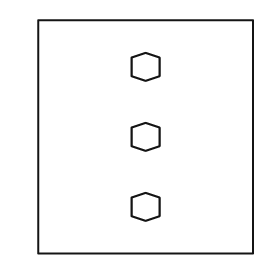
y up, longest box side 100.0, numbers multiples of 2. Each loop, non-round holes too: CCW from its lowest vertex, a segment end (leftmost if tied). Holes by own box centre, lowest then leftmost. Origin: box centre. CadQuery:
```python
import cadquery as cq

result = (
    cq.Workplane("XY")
    .moveTo(-46.0, -50.0)
    .lineTo(46.0, -50.0)
    .lineTo(46.0, 50.0)
    .lineTo(-46.0, 50.0)
    .close()
    .moveTo(0.0, -36.0)
    .lineTo(6.0, -34.0)
    .lineTo(6.0, -26.0)
    .lineTo(0.0, -24.0)
    .lineTo(-6.0, -26.0)
    .lineTo(-6.0, -34.0)
    .close()
    .moveTo(0.0, -6.0)
    .lineTo(6.0, -4.0)
    .lineTo(6.0, 4.0)
    .lineTo(0.0, 6.0)
    .lineTo(-6.0, 4.0)
    .lineTo(-6.0, -4.0)
    .close()
    .moveTo(0.0, 24.0)
    .lineTo(6.0, 26.0)
    .lineTo(6.0, 34.0)
    .lineTo(0.0, 36.0)
    .lineTo(-6.0, 34.0)
    .lineTo(-6.0, 26.0)
    .close()
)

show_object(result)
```